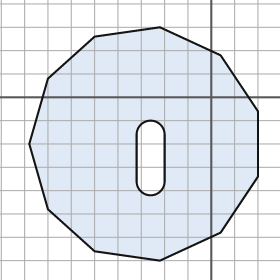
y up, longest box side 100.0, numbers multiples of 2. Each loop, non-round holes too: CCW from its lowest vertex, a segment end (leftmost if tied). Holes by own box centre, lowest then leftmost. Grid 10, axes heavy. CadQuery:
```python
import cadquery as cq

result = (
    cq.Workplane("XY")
    .moveTo(-22.0, -70.0)
    .lineTo(4.0, -58.0)
    .lineTo(20.0, -34.0)
    .lineTo(20.0, -6.0)
    .lineTo(4.0, 18.0)
    .lineTo(-22.0, 30.0)
    .lineTo(-50.0, 26.0)
    .lineTo(-70.0, 8.0)
    .lineTo(-78.0, -20.0)
    .lineTo(-70.0, -48.0)
    .lineTo(-50.0, -66.0)
    .close()
    .moveTo(-32.0, -36.0)
    .threePointArc((-26.0, -42.0), (-20.0, -36.0))
    .lineTo(-20.0, -16.0)
    .threePointArc((-26.0, -10.0), (-32.0, -16.0))
    .close()
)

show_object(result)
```